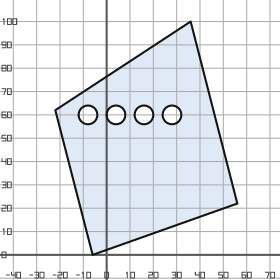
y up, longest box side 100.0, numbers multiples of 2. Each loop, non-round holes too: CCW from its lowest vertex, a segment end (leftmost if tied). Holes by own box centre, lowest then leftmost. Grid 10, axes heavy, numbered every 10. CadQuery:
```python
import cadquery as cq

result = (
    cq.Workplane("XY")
    .moveTo(-6.0, 0.0)
    .lineTo(56.0, 22.0)
    .lineTo(36.0, 100.0)
    .lineTo(-22.0, 62.0)
    .close()
    .moveTo(-8.0, 60.0)
    .circle(4.0)
    .moveTo(4.0, 60.0)
    .circle(4.0)
    .moveTo(16.0, 60.0)
    .circle(4.0)
    .moveTo(28.0, 60.0)
    .circle(4.0)
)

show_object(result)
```